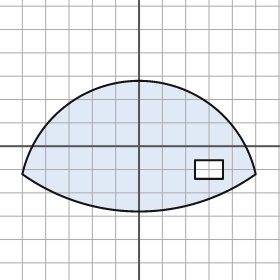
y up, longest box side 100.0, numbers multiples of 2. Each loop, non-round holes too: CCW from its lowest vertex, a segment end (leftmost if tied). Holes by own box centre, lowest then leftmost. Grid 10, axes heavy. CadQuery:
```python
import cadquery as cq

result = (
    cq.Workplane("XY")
    .moveTo(-50.0, -12.0)
    .threePointArc((0.0, -28.0), (50.0, -12.0))
    .threePointArc((0.0, 28.0), (-50.0, -12.0))
    .close()
    .moveTo(24.0, -14.0)
    .lineTo(36.0, -14.0)
    .lineTo(36.0, -6.0)
    .lineTo(24.0, -6.0)
    .close()
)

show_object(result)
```